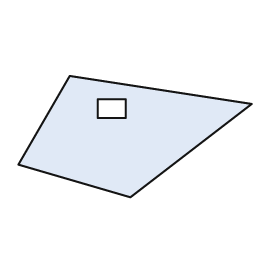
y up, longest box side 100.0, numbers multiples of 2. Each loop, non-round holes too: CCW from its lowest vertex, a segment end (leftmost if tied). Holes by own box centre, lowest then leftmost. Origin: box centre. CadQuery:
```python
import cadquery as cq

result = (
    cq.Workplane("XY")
    .moveTo(-2.0, -26.0)
    .lineTo(50.0, 14.0)
    .lineTo(-28.0, 26.0)
    .lineTo(-50.0, -12.0)
    .close()
    .moveTo(-16.0, 8.0)
    .lineTo(-4.0, 8.0)
    .lineTo(-4.0, 16.0)
    .lineTo(-16.0, 16.0)
    .close()
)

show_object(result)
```